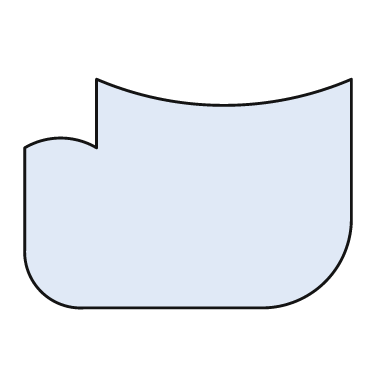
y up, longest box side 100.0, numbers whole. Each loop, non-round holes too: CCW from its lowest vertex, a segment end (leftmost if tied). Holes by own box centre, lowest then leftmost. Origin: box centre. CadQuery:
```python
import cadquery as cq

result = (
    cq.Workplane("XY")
    .moveTo(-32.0, -35.0)
    .lineTo(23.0, -35.0)
    .threePointArc((42.0, -27.0), (50.0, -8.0))
    .lineTo(50.0, 35.0)
    .threePointArc((11.0, 27.0), (-28.0, 35.0))
    .lineTo(-28.0, 14.0)
    .threePointArc((-39.0, 17.0), (-50.0, 14.0))
    .lineTo(-50.0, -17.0)
    .threePointArc((-45.0, -30.0), (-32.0, -35.0))
    .close()
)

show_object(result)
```